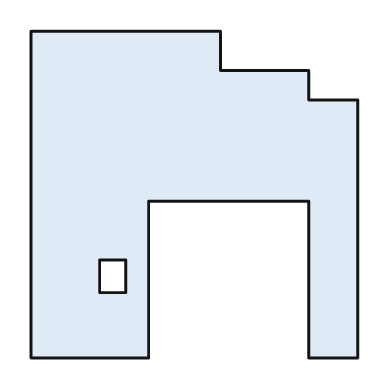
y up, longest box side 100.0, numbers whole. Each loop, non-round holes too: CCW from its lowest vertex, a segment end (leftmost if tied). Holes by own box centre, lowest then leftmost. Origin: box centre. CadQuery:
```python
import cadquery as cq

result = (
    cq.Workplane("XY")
    .moveTo(-50.0, -50.0)
    .lineTo(-14.0, -50.0)
    .lineTo(-14.0, -2.0)
    .lineTo(35.0, -2.0)
    .lineTo(35.0, -50.0)
    .lineTo(50.0, -50.0)
    .lineTo(50.0, 29.0)
    .lineTo(35.0, 29.0)
    .lineTo(35.0, 38.0)
    .lineTo(8.0, 38.0)
    .lineTo(8.0, 50.0)
    .lineTo(-50.0, 50.0)
    .close()
    .moveTo(-29.0, -30.0)
    .lineTo(-21.0, -30.0)
    .lineTo(-21.0, -20.0)
    .lineTo(-29.0, -20.0)
    .close()
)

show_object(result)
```